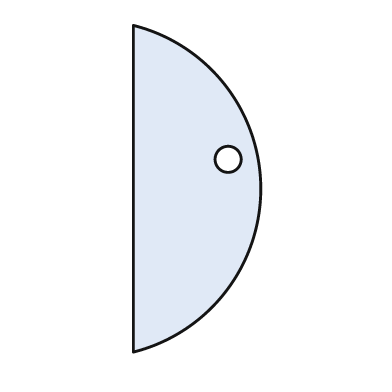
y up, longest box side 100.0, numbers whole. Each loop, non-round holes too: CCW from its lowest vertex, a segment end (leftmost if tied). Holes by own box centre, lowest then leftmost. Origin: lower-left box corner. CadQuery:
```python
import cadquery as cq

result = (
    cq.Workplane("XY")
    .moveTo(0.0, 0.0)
    .threePointArc((39.0, 50.0), (0.0, 100.0))
    .close()
    .moveTo(29.0, 59.0)
    .circle(4.0)
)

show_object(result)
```